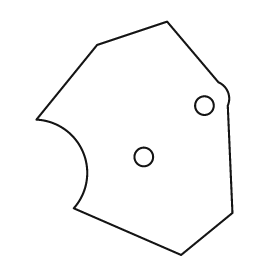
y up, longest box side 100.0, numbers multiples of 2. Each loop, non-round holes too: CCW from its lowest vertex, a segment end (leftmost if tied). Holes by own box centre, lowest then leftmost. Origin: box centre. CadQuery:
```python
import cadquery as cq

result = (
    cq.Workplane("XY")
    .moveTo(20.0, -50.0)
    .lineTo(42.0, -32.0)
    .lineTo(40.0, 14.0)
    .threePointArc((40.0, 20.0), (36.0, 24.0))
    .lineTo(14.0, 50.0)
    .lineTo(-16.0, 40.0)
    .lineTo(-42.0, 8.0)
    .threePointArc((-22.0, -6.0), (-26.0, -30.0))
    .close()
    .moveTo(4.0, -8.0)
    .circle(4.0)
    .moveTo(30.0, 14.0)
    .circle(4.0)
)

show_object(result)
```